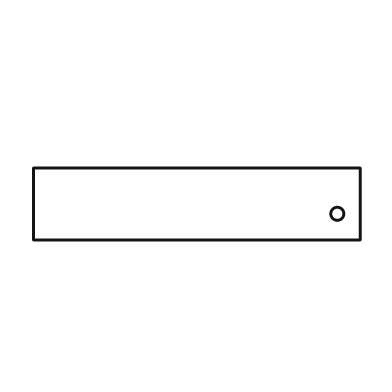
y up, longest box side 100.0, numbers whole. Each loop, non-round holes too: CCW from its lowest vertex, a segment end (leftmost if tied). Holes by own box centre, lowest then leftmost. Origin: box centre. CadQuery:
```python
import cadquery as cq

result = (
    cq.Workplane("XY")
    .moveTo(-50.0, -11.0)
    .lineTo(50.0, -11.0)
    .lineTo(50.0, 11.0)
    .lineTo(-50.0, 11.0)
    .close()
    .moveTo(43.0, -3.0)
    .circle(2.0)
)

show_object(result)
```